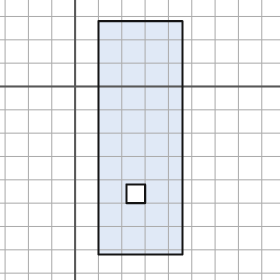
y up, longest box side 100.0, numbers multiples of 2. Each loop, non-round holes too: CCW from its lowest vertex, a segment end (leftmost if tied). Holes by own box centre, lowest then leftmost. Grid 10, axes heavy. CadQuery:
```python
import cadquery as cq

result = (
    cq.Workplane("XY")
    .moveTo(10.0, -72.0)
    .lineTo(46.0, -72.0)
    .lineTo(46.0, 28.0)
    .lineTo(10.0, 28.0)
    .close()
    .moveTo(22.0, -50.0)
    .lineTo(30.0, -50.0)
    .lineTo(30.0, -42.0)
    .lineTo(22.0, -42.0)
    .close()
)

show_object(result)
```